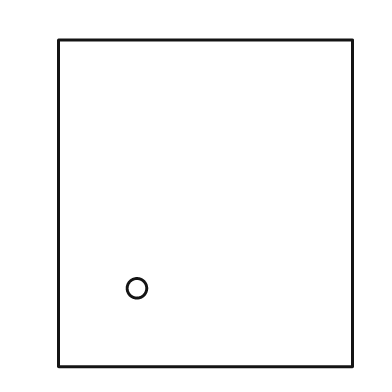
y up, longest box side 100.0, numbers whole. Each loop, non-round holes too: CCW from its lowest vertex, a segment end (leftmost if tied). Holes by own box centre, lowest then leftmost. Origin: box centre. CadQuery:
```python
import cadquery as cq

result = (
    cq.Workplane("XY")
    .moveTo(-45.0, -50.0)
    .lineTo(45.0, -50.0)
    .lineTo(45.0, 50.0)
    .lineTo(-45.0, 50.0)
    .close()
    .moveTo(-21.0, -26.0)
    .circle(3.0)
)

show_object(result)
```